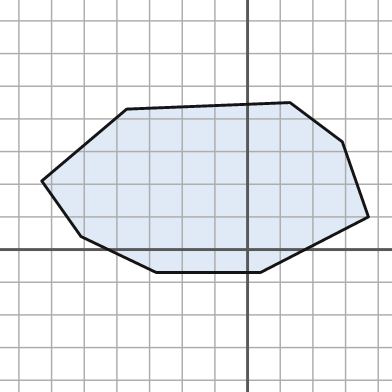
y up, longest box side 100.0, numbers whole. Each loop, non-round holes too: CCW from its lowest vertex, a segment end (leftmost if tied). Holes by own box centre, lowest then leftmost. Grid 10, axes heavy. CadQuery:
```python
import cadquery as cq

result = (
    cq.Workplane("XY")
    .moveTo(-28.0, -7.0)
    .lineTo(4.0, -7.0)
    .lineTo(37.0, 10.0)
    .lineTo(29.0, 33.0)
    .lineTo(13.0, 45.0)
    .lineTo(-37.0, 43.0)
    .lineTo(-63.0, 21.0)
    .lineTo(-51.0, 4.0)
    .close()
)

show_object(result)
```